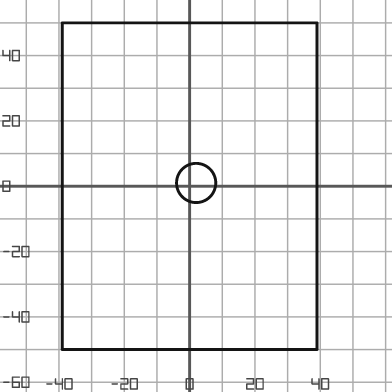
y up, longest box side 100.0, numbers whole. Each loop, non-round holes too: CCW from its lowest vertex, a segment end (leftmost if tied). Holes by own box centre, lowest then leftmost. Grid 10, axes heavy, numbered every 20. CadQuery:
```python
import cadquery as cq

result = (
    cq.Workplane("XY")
    .moveTo(-39.0, -50.0)
    .lineTo(39.0, -50.0)
    .lineTo(39.0, 50.0)
    .lineTo(-39.0, 50.0)
    .close()
    .moveTo(2.0, 1.0)
    .circle(6.0)
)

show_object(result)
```